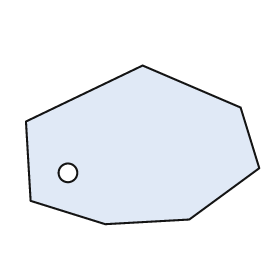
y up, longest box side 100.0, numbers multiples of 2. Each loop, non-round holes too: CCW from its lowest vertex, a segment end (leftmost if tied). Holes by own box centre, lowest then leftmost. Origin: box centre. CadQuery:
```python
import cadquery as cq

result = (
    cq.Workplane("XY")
    .moveTo(-16.0, -34.0)
    .lineTo(20.0, -32.0)
    .lineTo(50.0, -10.0)
    .lineTo(42.0, 16.0)
    .lineTo(0.0, 34.0)
    .lineTo(-50.0, 10.0)
    .lineTo(-48.0, -24.0)
    .close()
    .moveTo(-32.0, -12.0)
    .circle(4.0)
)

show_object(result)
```